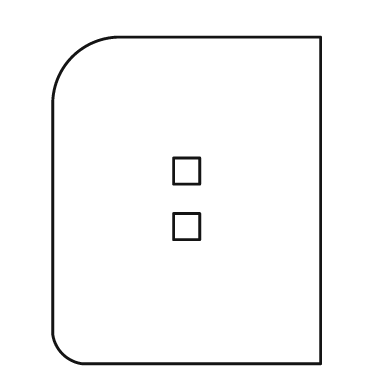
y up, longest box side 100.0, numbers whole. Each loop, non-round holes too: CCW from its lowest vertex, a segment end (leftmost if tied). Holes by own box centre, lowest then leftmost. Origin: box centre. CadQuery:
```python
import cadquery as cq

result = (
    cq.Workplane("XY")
    .moveTo(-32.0, -50.0)
    .lineTo(41.0, -50.0)
    .lineTo(41.0, 50.0)
    .lineTo(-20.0, 50.0)
    .threePointArc((-35.0, 44.0), (-41.0, 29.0))
    .lineTo(-41.0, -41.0)
    .threePointArc((-38.0, -47.0), (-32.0, -50.0))
    .close()
    .moveTo(-4.0, -12.0)
    .lineTo(4.0, -12.0)
    .lineTo(4.0, -4.0)
    .lineTo(-4.0, -4.0)
    .close()
    .moveTo(-4.0, 5.0)
    .lineTo(4.0, 5.0)
    .lineTo(4.0, 13.0)
    .lineTo(-4.0, 13.0)
    .close()
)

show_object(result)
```